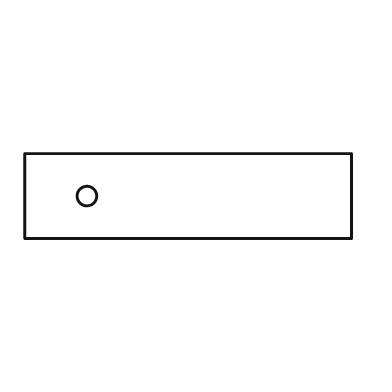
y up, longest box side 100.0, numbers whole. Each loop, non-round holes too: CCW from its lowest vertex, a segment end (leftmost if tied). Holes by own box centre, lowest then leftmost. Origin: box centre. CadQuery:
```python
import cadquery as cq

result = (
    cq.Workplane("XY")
    .moveTo(-50.0, -13.0)
    .lineTo(50.0, -13.0)
    .lineTo(50.0, 13.0)
    .lineTo(-50.0, 13.0)
    .close()
    .moveTo(-31.0, 0.0)
    .circle(3.0)
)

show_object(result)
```